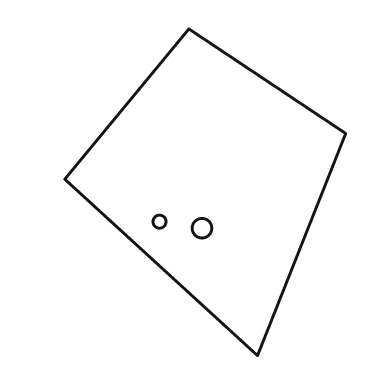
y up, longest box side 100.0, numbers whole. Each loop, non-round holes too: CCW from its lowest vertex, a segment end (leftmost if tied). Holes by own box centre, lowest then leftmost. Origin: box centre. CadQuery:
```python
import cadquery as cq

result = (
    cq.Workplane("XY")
    .moveTo(16.0, -50.0)
    .lineTo(43.0, 18.0)
    .lineTo(-5.0, 50.0)
    .lineTo(-43.0, 4.0)
    .close()
    .moveTo(-1.0, -11.0)
    .circle(3.0)
    .moveTo(-14.0, -9.0)
    .circle(2.0)
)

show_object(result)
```